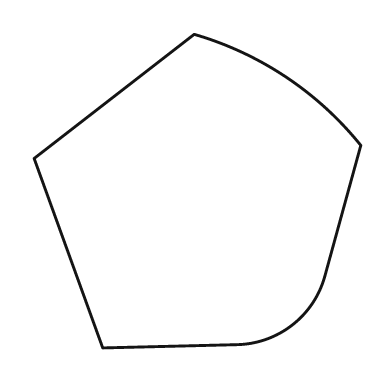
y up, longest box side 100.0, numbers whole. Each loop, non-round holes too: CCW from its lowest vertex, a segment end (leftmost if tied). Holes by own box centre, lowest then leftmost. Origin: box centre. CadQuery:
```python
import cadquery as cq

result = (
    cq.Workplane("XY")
    .moveTo(-29.0, -48.0)
    .lineTo(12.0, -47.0)
    .threePointArc((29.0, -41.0), (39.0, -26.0))
    .lineTo(50.0, 14.0)
    .threePointArc((27.0, 35.0), (-1.0, 48.0))
    .lineTo(-50.0, 10.0)
    .close()
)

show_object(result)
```